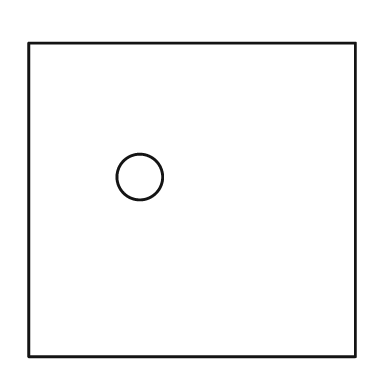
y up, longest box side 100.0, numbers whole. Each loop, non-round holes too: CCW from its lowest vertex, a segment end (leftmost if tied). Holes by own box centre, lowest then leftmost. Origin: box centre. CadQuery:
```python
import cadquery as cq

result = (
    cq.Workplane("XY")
    .moveTo(-50.0, -48.0)
    .lineTo(50.0, -48.0)
    .lineTo(50.0, 48.0)
    .lineTo(-50.0, 48.0)
    .close()
    .moveTo(-16.0, 7.0)
    .circle(7.0)
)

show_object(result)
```